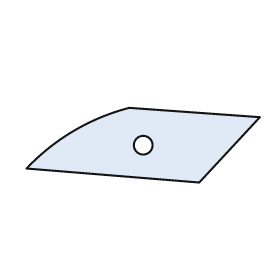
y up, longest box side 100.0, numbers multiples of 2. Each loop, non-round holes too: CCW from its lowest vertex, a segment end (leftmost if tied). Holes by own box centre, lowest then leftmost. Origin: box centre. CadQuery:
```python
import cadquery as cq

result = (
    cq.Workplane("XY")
    .moveTo(24.0, -16.0)
    .lineTo(50.0, 12.0)
    .lineTo(-6.0, 16.0)
    .threePointArc((-30.0, 6.0), (-50.0, -10.0))
    .close()
    .moveTo(0.0, 0.0)
    .circle(4.0)
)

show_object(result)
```